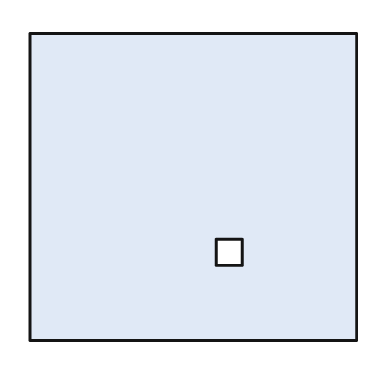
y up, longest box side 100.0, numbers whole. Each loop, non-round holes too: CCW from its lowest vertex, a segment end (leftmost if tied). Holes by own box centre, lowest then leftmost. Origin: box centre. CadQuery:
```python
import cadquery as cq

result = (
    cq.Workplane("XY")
    .moveTo(-50.0, -47.0)
    .lineTo(50.0, -47.0)
    .lineTo(50.0, 47.0)
    .lineTo(-50.0, 47.0)
    .close()
    .moveTo(7.0, -24.0)
    .lineTo(15.0, -24.0)
    .lineTo(15.0, -16.0)
    .lineTo(7.0, -16.0)
    .close()
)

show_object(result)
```